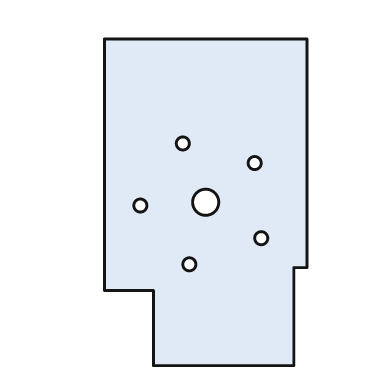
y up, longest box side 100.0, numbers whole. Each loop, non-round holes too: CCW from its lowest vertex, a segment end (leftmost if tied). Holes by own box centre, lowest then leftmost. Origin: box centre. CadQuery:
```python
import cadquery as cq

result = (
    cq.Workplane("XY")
    .moveTo(-16.0, -50.0)
    .lineTo(27.0, -50.0)
    .lineTo(27.0, -20.0)
    .lineTo(31.0, -20.0)
    .lineTo(31.0, 50.0)
    .lineTo(-31.0, 50.0)
    .lineTo(-31.0, -27.0)
    .lineTo(-16.0, -27.0)
    .close()
    .moveTo(-5.0, -19.0)
    .circle(2.0)
    .moveTo(17.0, -11.0)
    .circle(2.0)
    .moveTo(-20.0, -1.0)
    .circle(2.0)
    .moveTo(0.0, 0.0)
    .circle(4.0)
    .moveTo(15.0, 12.0)
    .circle(2.0)
    .moveTo(-7.0, 18.0)
    .circle(2.0)
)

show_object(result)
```